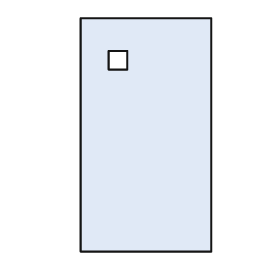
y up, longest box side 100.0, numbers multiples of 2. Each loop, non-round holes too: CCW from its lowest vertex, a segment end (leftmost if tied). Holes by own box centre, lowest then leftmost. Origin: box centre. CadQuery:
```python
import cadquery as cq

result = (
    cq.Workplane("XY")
    .moveTo(-28.0, -50.0)
    .lineTo(28.0, -50.0)
    .lineTo(28.0, 50.0)
    .lineTo(-28.0, 50.0)
    .close()
    .moveTo(-16.0, 28.0)
    .lineTo(-8.0, 28.0)
    .lineTo(-8.0, 36.0)
    .lineTo(-16.0, 36.0)
    .close()
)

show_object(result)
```